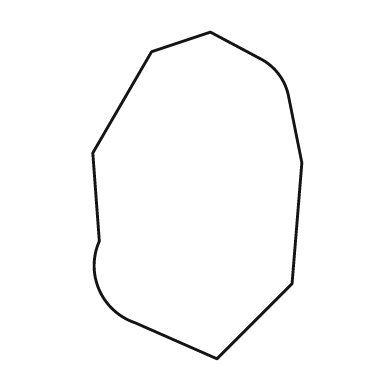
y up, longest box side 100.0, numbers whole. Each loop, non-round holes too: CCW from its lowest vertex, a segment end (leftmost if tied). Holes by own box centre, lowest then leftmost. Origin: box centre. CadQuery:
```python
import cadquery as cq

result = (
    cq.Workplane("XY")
    .moveTo(6.0, -50.0)
    .lineTo(29.0, -27.0)
    .lineTo(32.0, 10.0)
    .lineTo(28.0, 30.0)
    .threePointArc((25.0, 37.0), (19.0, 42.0))
    .lineTo(4.0, 50.0)
    .lineTo(-14.0, 44.0)
    .lineTo(-32.0, 13.0)
    .lineTo(-30.0, -14.0)
    .threePointArc((-30.0, -29.0), (-19.0, -39.0))
    .close()
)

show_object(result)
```